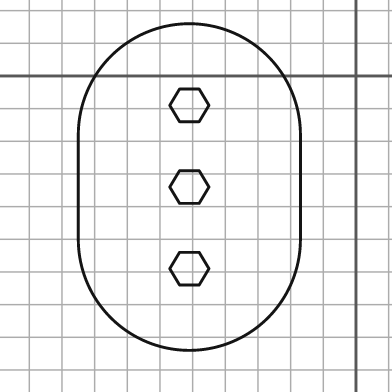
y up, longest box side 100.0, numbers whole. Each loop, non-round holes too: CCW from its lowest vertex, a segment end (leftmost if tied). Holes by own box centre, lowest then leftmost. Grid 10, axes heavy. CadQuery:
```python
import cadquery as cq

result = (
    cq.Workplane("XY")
    .moveTo(-85.0, -50.0)
    .threePointArc((-51.0, -84.0), (-17.0, -50.0))
    .lineTo(-17.0, -18.0)
    .threePointArc((-51.0, 16.0), (-85.0, -18.0))
    .close()
    .moveTo(-54.0, -64.0)
    .lineTo(-48.0, -64.0)
    .lineTo(-45.0, -59.0)
    .lineTo(-48.0, -54.0)
    .lineTo(-54.0, -54.0)
    .lineTo(-57.0, -59.0)
    .close()
    .moveTo(-54.0, -39.0)
    .lineTo(-48.0, -39.0)
    .lineTo(-45.0, -34.0)
    .lineTo(-48.0, -29.0)
    .lineTo(-54.0, -29.0)
    .lineTo(-57.0, -34.0)
    .close()
    .moveTo(-54.0, -14.0)
    .lineTo(-48.0, -14.0)
    .lineTo(-45.0, -9.0)
    .lineTo(-48.0, -4.0)
    .lineTo(-54.0, -4.0)
    .lineTo(-57.0, -9.0)
    .close()
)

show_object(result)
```